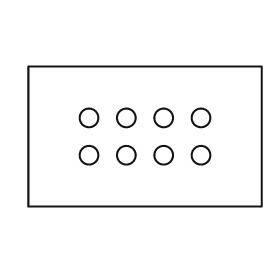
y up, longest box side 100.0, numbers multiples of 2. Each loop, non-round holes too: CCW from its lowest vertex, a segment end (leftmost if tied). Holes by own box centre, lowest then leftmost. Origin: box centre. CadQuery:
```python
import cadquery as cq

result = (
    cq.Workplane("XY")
    .moveTo(-50.0, -30.0)
    .lineTo(50.0, -30.0)
    .lineTo(50.0, 30.0)
    .lineTo(-50.0, 30.0)
    .close()
    .moveTo(-24.0, -8.0)
    .circle(4.0)
    .moveTo(-8.0, -8.0)
    .circle(4.0)
    .moveTo(8.0, -8.0)
    .circle(4.0)
    .moveTo(24.0, -8.0)
    .circle(4.0)
    .moveTo(-24.0, 8.0)
    .circle(4.0)
    .moveTo(-8.0, 8.0)
    .circle(4.0)
    .moveTo(8.0, 8.0)
    .circle(4.0)
    .moveTo(24.0, 8.0)
    .circle(4.0)
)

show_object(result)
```